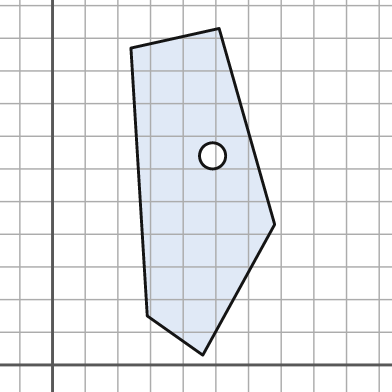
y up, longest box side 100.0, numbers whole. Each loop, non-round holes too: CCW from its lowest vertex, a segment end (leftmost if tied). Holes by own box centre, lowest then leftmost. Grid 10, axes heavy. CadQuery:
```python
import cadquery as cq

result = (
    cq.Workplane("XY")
    .moveTo(46.0, 3.0)
    .lineTo(68.0, 43.0)
    .lineTo(51.0, 103.0)
    .lineTo(24.0, 97.0)
    .lineTo(29.0, 15.0)
    .close()
    .moveTo(49.0, 64.0)
    .circle(4.0)
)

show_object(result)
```